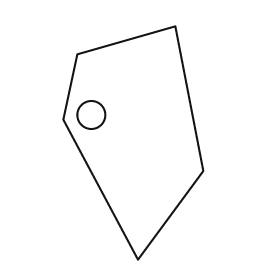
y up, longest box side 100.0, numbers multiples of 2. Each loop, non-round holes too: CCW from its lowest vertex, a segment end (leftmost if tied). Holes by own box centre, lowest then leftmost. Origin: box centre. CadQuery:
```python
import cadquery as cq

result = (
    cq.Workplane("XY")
    .moveTo(2.0, -50.0)
    .lineTo(30.0, -12.0)
    .lineTo(18.0, 50.0)
    .lineTo(-24.0, 38.0)
    .lineTo(-30.0, 10.0)
    .close()
    .moveTo(-18.0, 12.0)
    .circle(6.0)
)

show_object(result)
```